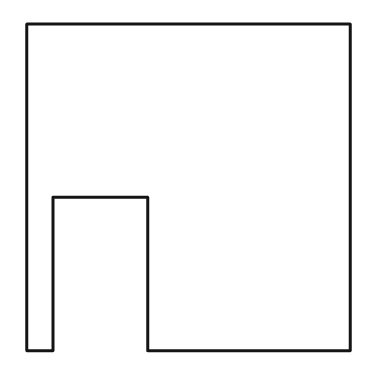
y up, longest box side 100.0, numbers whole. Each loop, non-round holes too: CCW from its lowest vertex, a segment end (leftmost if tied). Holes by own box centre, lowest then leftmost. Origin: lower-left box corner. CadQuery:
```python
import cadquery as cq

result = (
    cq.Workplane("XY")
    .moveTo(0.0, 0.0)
    .lineTo(8.0, 0.0)
    .lineTo(8.0, 47.0)
    .lineTo(37.0, 47.0)
    .lineTo(37.0, 0.0)
    .lineTo(99.0, 0.0)
    .lineTo(99.0, 100.0)
    .lineTo(0.0, 100.0)
    .close()
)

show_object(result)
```